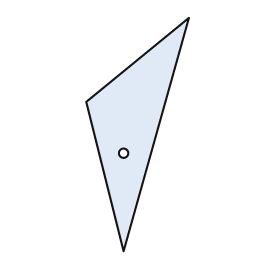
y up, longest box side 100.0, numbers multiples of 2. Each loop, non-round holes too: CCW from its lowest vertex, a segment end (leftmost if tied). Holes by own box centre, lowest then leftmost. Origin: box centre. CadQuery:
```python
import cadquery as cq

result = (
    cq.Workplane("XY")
    .moveTo(-6.0, -50.0)
    .lineTo(22.0, 50.0)
    .lineTo(-22.0, 14.0)
    .close()
    .moveTo(-6.0, -8.0)
    .circle(2.0)
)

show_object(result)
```